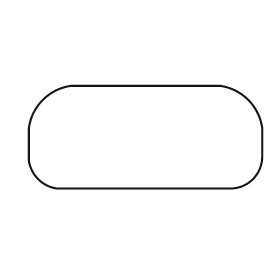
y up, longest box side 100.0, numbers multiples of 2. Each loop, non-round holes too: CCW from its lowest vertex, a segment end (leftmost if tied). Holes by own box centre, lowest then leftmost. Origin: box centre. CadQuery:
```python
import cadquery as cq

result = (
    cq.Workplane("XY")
    .moveTo(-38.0, -22.0)
    .lineTo(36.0, -22.0)
    .threePointArc((46.0, -18.0), (50.0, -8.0))
    .lineTo(50.0, 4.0)
    .threePointArc((44.0, 16.0), (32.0, 22.0))
    .lineTo(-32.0, 22.0)
    .threePointArc((-44.0, 16.0), (-50.0, 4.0))
    .lineTo(-50.0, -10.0)
    .threePointArc((-46.0, -18.0), (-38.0, -22.0))
    .close()
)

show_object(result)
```